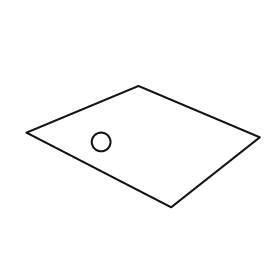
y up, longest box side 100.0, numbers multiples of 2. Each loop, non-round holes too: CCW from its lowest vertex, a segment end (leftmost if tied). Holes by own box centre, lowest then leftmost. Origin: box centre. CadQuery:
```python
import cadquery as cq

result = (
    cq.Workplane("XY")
    .moveTo(12.0, -26.0)
    .lineTo(50.0, 4.0)
    .lineTo(-2.0, 26.0)
    .lineTo(-50.0, 6.0)
    .close()
    .moveTo(-18.0, 2.0)
    .circle(4.0)
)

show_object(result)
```